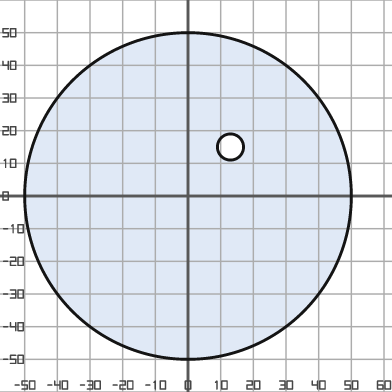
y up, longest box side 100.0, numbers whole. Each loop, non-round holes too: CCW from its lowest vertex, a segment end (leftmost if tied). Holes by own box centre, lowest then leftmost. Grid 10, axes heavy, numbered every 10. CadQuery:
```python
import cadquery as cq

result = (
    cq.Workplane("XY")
    .moveTo(0.0, 0.0)
    .circle(50.0)
    .moveTo(13.0, 15.0)
    .circle(4.0)
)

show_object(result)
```